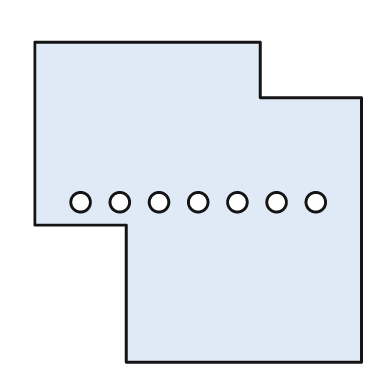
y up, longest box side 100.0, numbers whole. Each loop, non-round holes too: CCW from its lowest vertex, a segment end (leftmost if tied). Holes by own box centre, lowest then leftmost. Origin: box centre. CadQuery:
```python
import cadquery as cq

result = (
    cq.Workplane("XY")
    .moveTo(-22.0, -49.0)
    .lineTo(50.0, -49.0)
    .lineTo(50.0, 32.0)
    .lineTo(19.0, 32.0)
    .lineTo(19.0, 49.0)
    .lineTo(-50.0, 49.0)
    .lineTo(-50.0, -7.0)
    .lineTo(-22.0, -7.0)
    .close()
    .moveTo(-36.0, 0.0)
    .circle(3.0)
    .moveTo(-24.0, 0.0)
    .circle(3.0)
    .moveTo(-12.0, 0.0)
    .circle(3.0)
    .moveTo(0.0, 0.0)
    .circle(3.0)
    .moveTo(12.0, 0.0)
    .circle(3.0)
    .moveTo(24.0, 0.0)
    .circle(3.0)
    .moveTo(36.0, 0.0)
    .circle(3.0)
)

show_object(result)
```